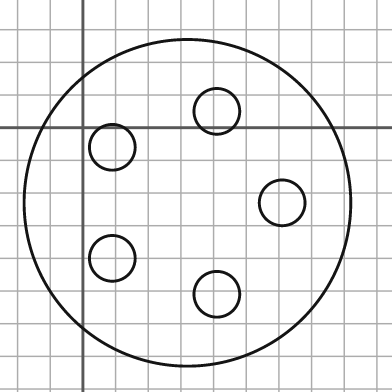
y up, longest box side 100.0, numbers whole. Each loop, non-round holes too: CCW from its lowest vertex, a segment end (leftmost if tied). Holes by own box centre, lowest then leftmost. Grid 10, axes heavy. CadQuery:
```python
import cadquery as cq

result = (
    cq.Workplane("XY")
    .moveTo(32.0, -23.0)
    .circle(50.0)
    .moveTo(41.0, -51.0)
    .circle(7.0)
    .moveTo(9.0, -40.0)
    .circle(7.0)
    .moveTo(61.0, -23.0)
    .circle(7.0)
    .moveTo(9.0, -6.0)
    .circle(7.0)
    .moveTo(41.0, 5.0)
    .circle(7.0)
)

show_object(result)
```